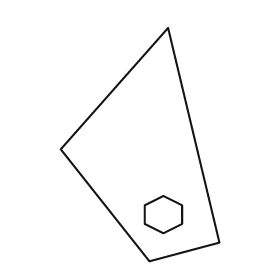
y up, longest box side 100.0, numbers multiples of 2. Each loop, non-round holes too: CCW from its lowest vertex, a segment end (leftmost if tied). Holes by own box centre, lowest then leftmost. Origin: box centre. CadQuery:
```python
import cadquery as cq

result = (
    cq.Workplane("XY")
    .moveTo(4.0, -50.0)
    .lineTo(34.0, -42.0)
    .lineTo(12.0, 50.0)
    .lineTo(-34.0, -2.0)
    .close()
    .moveTo(10.0, -38.0)
    .lineTo(18.0, -34.0)
    .lineTo(18.0, -26.0)
    .lineTo(10.0, -22.0)
    .lineTo(2.0, -26.0)
    .lineTo(2.0, -34.0)
    .close()
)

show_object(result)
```